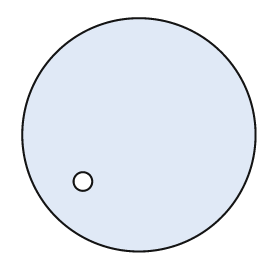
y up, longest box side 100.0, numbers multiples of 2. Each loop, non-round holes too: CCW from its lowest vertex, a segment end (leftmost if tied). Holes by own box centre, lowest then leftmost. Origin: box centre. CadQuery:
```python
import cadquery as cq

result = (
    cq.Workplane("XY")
    .moveTo(0.0, 0.0)
    .circle(50.0)
    .moveTo(-24.0, -20.0)
    .circle(4.0)
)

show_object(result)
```